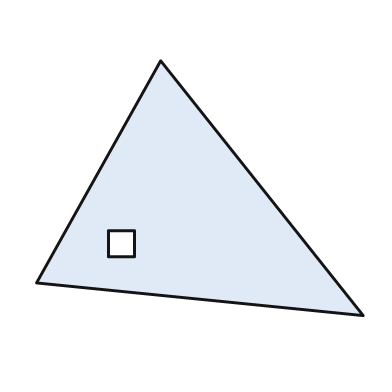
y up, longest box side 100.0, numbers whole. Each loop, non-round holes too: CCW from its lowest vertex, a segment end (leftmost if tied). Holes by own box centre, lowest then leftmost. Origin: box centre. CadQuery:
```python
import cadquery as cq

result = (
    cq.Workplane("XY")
    .moveTo(50.0, -39.0)
    .lineTo(-12.0, 39.0)
    .lineTo(-50.0, -29.0)
    .close()
    .moveTo(-28.0, -21.0)
    .lineTo(-20.0, -21.0)
    .lineTo(-20.0, -13.0)
    .lineTo(-28.0, -13.0)
    .close()
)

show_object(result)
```